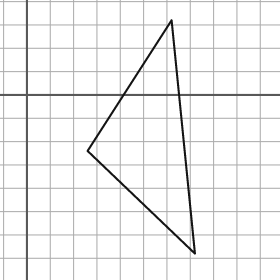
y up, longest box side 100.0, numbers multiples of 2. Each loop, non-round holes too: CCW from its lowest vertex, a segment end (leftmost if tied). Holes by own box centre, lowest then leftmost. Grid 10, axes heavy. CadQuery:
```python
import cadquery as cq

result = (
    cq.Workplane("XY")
    .moveTo(72.0, -68.0)
    .lineTo(62.0, 32.0)
    .lineTo(26.0, -24.0)
    .close()
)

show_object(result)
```